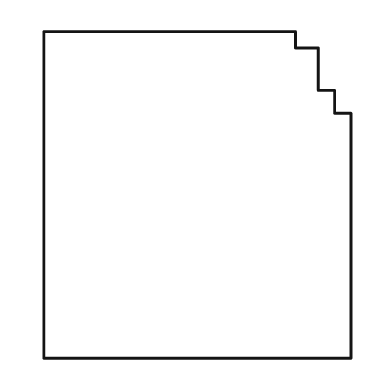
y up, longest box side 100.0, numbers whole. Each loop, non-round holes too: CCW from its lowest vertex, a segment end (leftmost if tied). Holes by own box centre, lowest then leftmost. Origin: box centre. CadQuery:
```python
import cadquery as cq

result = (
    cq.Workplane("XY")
    .moveTo(-47.0, -50.0)
    .lineTo(47.0, -50.0)
    .lineTo(47.0, 25.0)
    .lineTo(42.0, 25.0)
    .lineTo(42.0, 32.0)
    .lineTo(37.0, 32.0)
    .lineTo(37.0, 45.0)
    .lineTo(30.0, 45.0)
    .lineTo(30.0, 50.0)
    .lineTo(-47.0, 50.0)
    .close()
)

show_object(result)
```